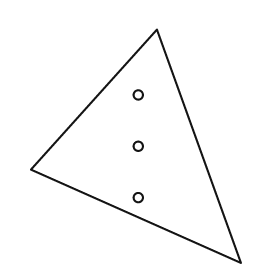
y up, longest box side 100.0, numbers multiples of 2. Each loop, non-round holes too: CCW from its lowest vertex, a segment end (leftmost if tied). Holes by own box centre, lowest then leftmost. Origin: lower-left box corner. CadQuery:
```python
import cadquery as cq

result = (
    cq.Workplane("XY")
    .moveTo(90.0, 0.0)
    .lineTo(54.0, 100.0)
    .lineTo(0.0, 40.0)
    .close()
    .moveTo(46.0, 28.0)
    .circle(2.0)
    .moveTo(46.0, 50.0)
    .circle(2.0)
    .moveTo(46.0, 72.0)
    .circle(2.0)
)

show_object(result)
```